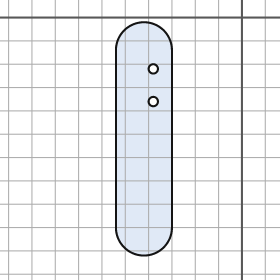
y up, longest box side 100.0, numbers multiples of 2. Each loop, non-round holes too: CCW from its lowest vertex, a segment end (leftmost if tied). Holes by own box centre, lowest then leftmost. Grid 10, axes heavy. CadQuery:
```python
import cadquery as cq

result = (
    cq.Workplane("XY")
    .moveTo(-54.0, -90.0)
    .threePointArc((-42.0, -102.0), (-30.0, -90.0))
    .lineTo(-30.0, -14.0)
    .threePointArc((-42.0, -2.0), (-54.0, -14.0))
    .close()
    .moveTo(-38.0, -36.0)
    .circle(2.0)
    .moveTo(-38.0, -22.0)
    .circle(2.0)
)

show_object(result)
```